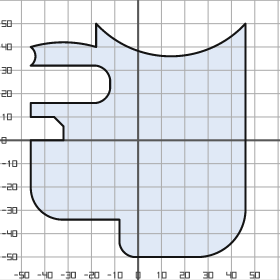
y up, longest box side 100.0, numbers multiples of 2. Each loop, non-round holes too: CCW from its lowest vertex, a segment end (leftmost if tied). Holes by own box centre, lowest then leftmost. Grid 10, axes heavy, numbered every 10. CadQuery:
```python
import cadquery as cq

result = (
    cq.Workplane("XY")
    .moveTo(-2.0, -50.0)
    .lineTo(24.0, -50.0)
    .threePointArc((40.0, -44.0), (46.0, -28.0))
    .lineTo(46.0, 50.0)
    .threePointArc((14.0, 36.0), (-18.0, 50.0))
    .lineTo(-18.0, 40.0)
    .threePointArc((-32.0, 42.0), (-46.0, 40.0))
    .threePointArc((-44.0, 36.0), (-46.0, 32.0))
    .lineTo(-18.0, 32.0)
    .threePointArc((-14.0, 30.0), (-12.0, 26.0))
    .lineTo(-12.0, 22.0)
    .threePointArc((-14.0, 18.0), (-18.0, 16.0))
    .lineTo(-46.0, 16.0)
    .lineTo(-46.0, 10.0)
    .lineTo(-36.0, 10.0)
    .lineTo(-32.0, 6.0)
    .lineTo(-32.0, 0.0)
    .lineTo(-46.0, 0.0)
    .lineTo(-46.0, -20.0)
    .threePointArc((-42.0, -30.0), (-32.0, -34.0))
    .lineTo(-8.0, -34.0)
    .lineTo(-8.0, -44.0)
    .threePointArc((-6.0, -48.0), (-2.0, -50.0))
    .close()
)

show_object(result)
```